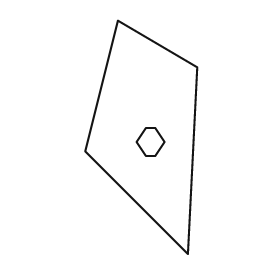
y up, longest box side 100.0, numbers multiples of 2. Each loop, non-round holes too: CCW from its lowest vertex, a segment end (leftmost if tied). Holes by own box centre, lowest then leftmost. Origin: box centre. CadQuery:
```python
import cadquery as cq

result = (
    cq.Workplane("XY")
    .moveTo(20.0, -50.0)
    .lineTo(24.0, 30.0)
    .lineTo(-10.0, 50.0)
    .lineTo(-24.0, -6.0)
    .close()
    .moveTo(2.0, -8.0)
    .lineTo(6.0, -8.0)
    .lineTo(10.0, -2.0)
    .lineTo(6.0, 4.0)
    .lineTo(2.0, 4.0)
    .lineTo(-2.0, -2.0)
    .close()
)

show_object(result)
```